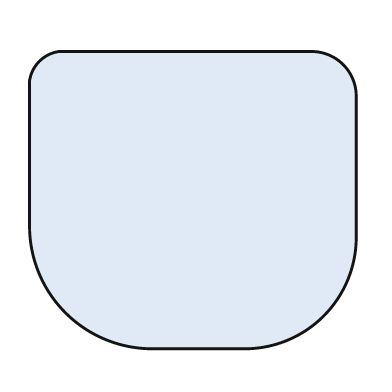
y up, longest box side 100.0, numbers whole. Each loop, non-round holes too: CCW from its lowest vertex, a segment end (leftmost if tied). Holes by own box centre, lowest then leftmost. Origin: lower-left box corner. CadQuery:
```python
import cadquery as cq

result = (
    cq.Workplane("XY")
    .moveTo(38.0, 0.0)
    .lineTo(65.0, 0.0)
    .threePointArc((90.0, 10.0), (100.0, 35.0))
    .lineTo(100.0, 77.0)
    .threePointArc((96.0, 87.0), (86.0, 91.0))
    .lineTo(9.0, 91.0)
    .threePointArc((3.0, 88.0), (0.0, 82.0))
    .lineTo(0.0, 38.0)
    .threePointArc((11.0, 11.0), (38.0, 0.0))
    .close()
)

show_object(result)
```